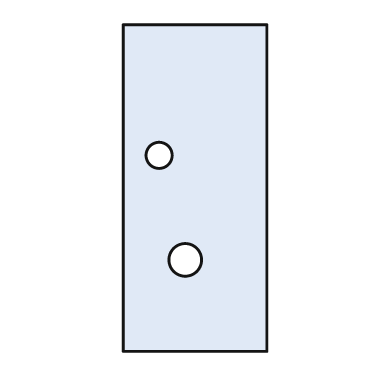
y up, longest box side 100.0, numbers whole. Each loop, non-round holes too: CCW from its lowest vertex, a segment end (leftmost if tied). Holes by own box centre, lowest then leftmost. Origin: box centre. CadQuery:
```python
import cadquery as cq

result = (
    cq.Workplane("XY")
    .moveTo(-22.0, -50.0)
    .lineTo(22.0, -50.0)
    .lineTo(22.0, 50.0)
    .lineTo(-22.0, 50.0)
    .close()
    .moveTo(-3.0, -22.0)
    .circle(5.0)
    .moveTo(-11.0, 10.0)
    .circle(4.0)
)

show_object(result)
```